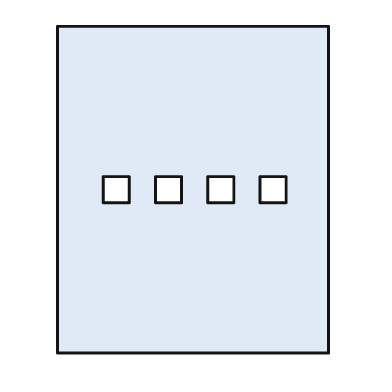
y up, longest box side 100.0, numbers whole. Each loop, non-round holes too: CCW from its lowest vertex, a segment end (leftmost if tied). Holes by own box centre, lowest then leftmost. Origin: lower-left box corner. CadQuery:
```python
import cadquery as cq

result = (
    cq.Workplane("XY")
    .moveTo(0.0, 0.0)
    .lineTo(83.0, 0.0)
    .lineTo(83.0, 100.0)
    .lineTo(0.0, 100.0)
    .close()
    .moveTo(14.0, 46.0)
    .lineTo(22.0, 46.0)
    .lineTo(22.0, 54.0)
    .lineTo(14.0, 54.0)
    .close()
    .moveTo(30.0, 46.0)
    .lineTo(38.0, 46.0)
    .lineTo(38.0, 54.0)
    .lineTo(30.0, 54.0)
    .close()
    .moveTo(46.0, 46.0)
    .lineTo(54.0, 46.0)
    .lineTo(54.0, 54.0)
    .lineTo(46.0, 54.0)
    .close()
    .moveTo(62.0, 46.0)
    .lineTo(70.0, 46.0)
    .lineTo(70.0, 54.0)
    .lineTo(62.0, 54.0)
    .close()
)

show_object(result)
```